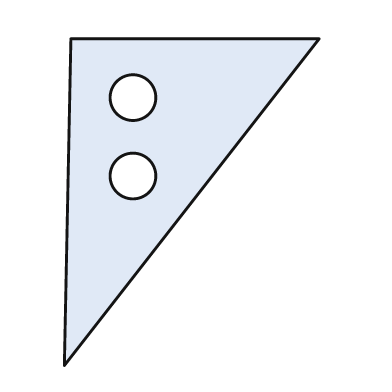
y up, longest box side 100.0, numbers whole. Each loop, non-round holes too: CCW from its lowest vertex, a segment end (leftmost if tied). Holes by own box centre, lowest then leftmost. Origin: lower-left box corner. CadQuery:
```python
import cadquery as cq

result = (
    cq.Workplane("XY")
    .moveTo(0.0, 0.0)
    .lineTo(78.0, 100.0)
    .lineTo(2.0, 100.0)
    .close()
    .moveTo(21.0, 58.0)
    .circle(7.0)
    .moveTo(21.0, 82.0)
    .circle(7.0)
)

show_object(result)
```